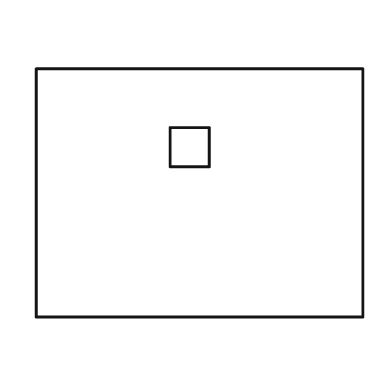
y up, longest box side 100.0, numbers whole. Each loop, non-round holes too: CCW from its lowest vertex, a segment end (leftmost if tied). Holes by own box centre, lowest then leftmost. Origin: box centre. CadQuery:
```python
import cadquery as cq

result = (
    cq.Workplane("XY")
    .moveTo(-50.0, -38.0)
    .lineTo(50.0, -38.0)
    .lineTo(50.0, 38.0)
    .lineTo(-50.0, 38.0)
    .close()
    .moveTo(-9.0, 8.0)
    .lineTo(3.0, 8.0)
    .lineTo(3.0, 20.0)
    .lineTo(-9.0, 20.0)
    .close()
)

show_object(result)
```